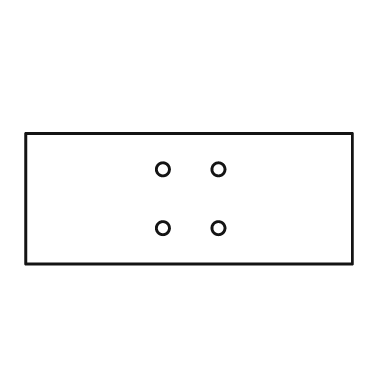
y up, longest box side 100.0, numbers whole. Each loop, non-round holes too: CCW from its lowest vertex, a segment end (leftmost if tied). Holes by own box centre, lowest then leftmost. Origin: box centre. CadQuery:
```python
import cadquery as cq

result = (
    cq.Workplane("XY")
    .moveTo(-50.0, -20.0)
    .lineTo(50.0, -20.0)
    .lineTo(50.0, 20.0)
    .lineTo(-50.0, 20.0)
    .close()
    .moveTo(-8.0, -9.0)
    .circle(2.0)
    .moveTo(9.0, -9.0)
    .circle(2.0)
    .moveTo(-8.0, 9.0)
    .circle(2.0)
    .moveTo(9.0, 9.0)
    .circle(2.0)
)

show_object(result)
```